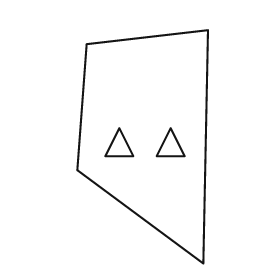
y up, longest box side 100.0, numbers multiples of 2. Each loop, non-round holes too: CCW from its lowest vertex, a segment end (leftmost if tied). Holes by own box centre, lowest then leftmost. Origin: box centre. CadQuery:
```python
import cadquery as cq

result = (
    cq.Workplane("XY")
    .moveTo(26.0, -50.0)
    .lineTo(28.0, 50.0)
    .lineTo(-24.0, 44.0)
    .lineTo(-28.0, -10.0)
    .close()
    .moveTo(-16.0, -4.0)
    .lineTo(-4.0, -4.0)
    .lineTo(-10.0, 8.0)
    .close()
    .moveTo(6.0, -4.0)
    .lineTo(18.0, -4.0)
    .lineTo(12.0, 8.0)
    .close()
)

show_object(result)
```